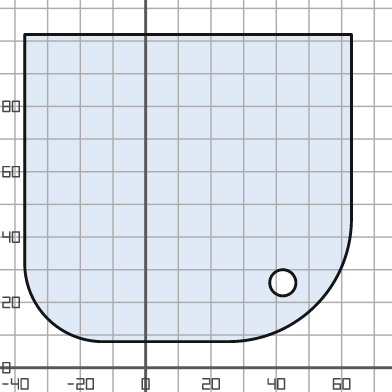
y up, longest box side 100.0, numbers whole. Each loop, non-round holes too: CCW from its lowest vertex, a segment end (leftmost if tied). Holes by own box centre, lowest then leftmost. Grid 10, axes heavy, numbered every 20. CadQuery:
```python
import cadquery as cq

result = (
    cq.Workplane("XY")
    .moveTo(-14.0, 8.0)
    .lineTo(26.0, 8.0)
    .threePointArc((52.0, 19.0), (63.0, 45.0))
    .lineTo(63.0, 102.0)
    .lineTo(-37.0, 102.0)
    .lineTo(-37.0, 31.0)
    .threePointArc((-30.0, 15.0), (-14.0, 8.0))
    .close()
    .moveTo(42.0, 26.0)
    .circle(4.0)
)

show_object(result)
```